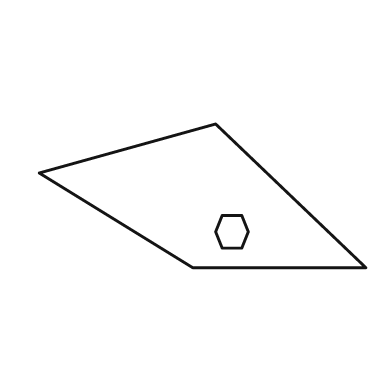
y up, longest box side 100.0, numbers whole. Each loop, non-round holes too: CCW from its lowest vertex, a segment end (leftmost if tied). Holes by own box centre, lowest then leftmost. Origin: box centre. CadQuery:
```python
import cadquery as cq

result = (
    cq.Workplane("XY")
    .moveTo(-3.0, -22.0)
    .lineTo(50.0, -22.0)
    .lineTo(4.0, 22.0)
    .lineTo(-50.0, 7.0)
    .close()
    .moveTo(6.0, -16.0)
    .lineTo(12.0, -16.0)
    .lineTo(14.0, -11.0)
    .lineTo(12.0, -6.0)
    .lineTo(6.0, -6.0)
    .lineTo(4.0, -11.0)
    .close()
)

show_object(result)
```